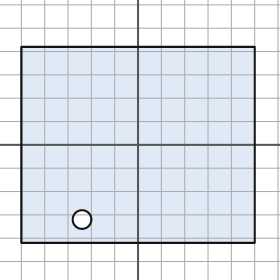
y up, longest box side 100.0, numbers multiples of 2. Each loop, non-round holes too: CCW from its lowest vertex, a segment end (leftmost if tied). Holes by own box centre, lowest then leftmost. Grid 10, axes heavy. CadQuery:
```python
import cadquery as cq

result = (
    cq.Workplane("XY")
    .moveTo(-50.0, -42.0)
    .lineTo(50.0, -42.0)
    .lineTo(50.0, 42.0)
    .lineTo(-50.0, 42.0)
    .close()
    .moveTo(-24.0, -32.0)
    .circle(4.0)
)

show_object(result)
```